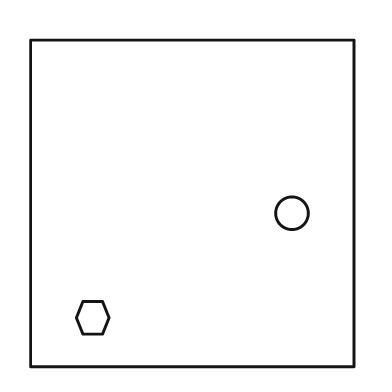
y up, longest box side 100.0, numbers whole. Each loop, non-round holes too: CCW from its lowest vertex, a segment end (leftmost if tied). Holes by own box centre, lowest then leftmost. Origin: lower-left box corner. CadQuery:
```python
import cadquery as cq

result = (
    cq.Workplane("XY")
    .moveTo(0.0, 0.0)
    .lineTo(99.0, 0.0)
    .lineTo(99.0, 100.0)
    .lineTo(0.0, 100.0)
    .close()
    .moveTo(16.0, 10.0)
    .lineTo(22.0, 10.0)
    .lineTo(24.0, 15.0)
    .lineTo(22.0, 20.0)
    .lineTo(16.0, 20.0)
    .lineTo(14.0, 15.0)
    .close()
    .moveTo(80.0, 47.0)
    .circle(5.0)
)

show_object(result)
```